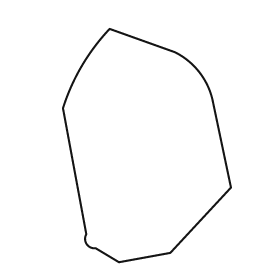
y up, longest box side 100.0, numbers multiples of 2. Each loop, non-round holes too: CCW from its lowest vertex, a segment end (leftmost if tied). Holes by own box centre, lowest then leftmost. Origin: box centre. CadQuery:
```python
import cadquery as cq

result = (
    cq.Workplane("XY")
    .moveTo(-12.0, -50.0)
    .lineTo(10.0, -46.0)
    .lineTo(36.0, -18.0)
    .lineTo(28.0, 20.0)
    .threePointArc((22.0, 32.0), (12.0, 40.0))
    .lineTo(-16.0, 50.0)
    .threePointArc((-28.0, 34.0), (-36.0, 16.0))
    .lineTo(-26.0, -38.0)
    .threePointArc((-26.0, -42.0), (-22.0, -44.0))
    .close()
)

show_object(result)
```